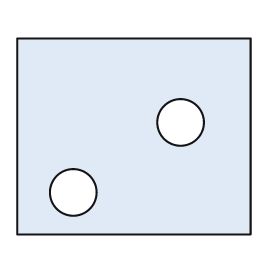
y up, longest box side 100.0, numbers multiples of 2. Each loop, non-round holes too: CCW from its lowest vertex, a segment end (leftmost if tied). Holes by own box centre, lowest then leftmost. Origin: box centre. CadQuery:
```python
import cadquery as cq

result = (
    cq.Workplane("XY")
    .moveTo(-50.0, -42.0)
    .lineTo(50.0, -42.0)
    .lineTo(50.0, 42.0)
    .lineTo(-50.0, 42.0)
    .close()
    .moveTo(-26.0, -24.0)
    .circle(10.0)
    .moveTo(20.0, 6.0)
    .circle(10.0)
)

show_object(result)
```